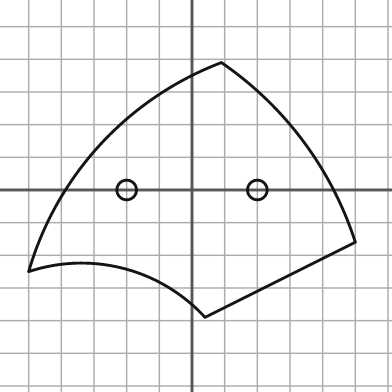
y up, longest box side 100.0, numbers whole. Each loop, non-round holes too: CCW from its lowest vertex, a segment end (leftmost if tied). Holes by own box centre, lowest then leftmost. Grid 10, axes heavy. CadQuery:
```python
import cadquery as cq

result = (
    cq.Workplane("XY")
    .moveTo(4.0, -39.0)
    .lineTo(50.0, -16.0)
    .threePointArc((34.0, 15.0), (9.0, 39.0))
    .threePointArc((-28.0, 14.0), (-50.0, -25.0))
    .threePointArc((-21.0, -24.0), (4.0, -39.0))
    .close()
    .moveTo(-20.0, 0.0)
    .circle(3.0)
    .moveTo(20.0, 0.0)
    .circle(3.0)
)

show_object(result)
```